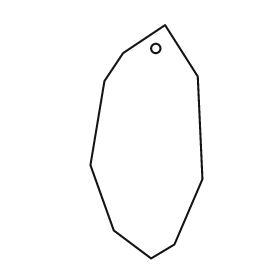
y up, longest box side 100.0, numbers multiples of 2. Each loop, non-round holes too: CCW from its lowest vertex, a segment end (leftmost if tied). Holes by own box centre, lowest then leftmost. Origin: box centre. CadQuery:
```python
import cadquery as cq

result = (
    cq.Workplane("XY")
    .moveTo(2.0, -50.0)
    .lineTo(12.0, -44.0)
    .lineTo(24.0, -16.0)
    .lineTo(22.0, 28.0)
    .lineTo(8.0, 50.0)
    .lineTo(-10.0, 38.0)
    .lineTo(-18.0, 26.0)
    .lineTo(-24.0, -10.0)
    .lineTo(-14.0, -38.0)
    .close()
    .moveTo(4.0, 40.0)
    .circle(2.0)
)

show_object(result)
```